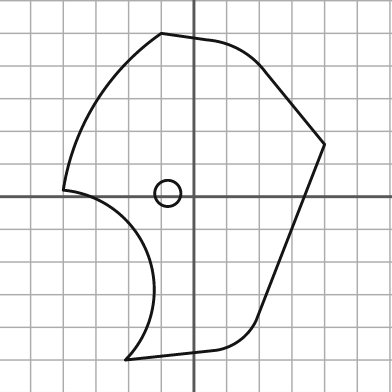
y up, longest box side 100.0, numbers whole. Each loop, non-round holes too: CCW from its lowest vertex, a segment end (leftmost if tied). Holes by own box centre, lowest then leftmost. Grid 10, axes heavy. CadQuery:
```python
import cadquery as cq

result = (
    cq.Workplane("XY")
    .moveTo(-21.0, -50.0)
    .lineTo(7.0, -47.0)
    .threePointArc((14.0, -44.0), (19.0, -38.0))
    .lineTo(40.0, 16.0)
    .lineTo(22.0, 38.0)
    .threePointArc((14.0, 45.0), (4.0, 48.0))
    .lineTo(-10.0, 50.0)
    .threePointArc((-30.0, 29.0), (-40.0, 2.0))
    .threePointArc((-14.0, -18.0), (-21.0, -50.0))
    .close()
    .moveTo(-8.0, 1.0)
    .circle(4.0)
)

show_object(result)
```